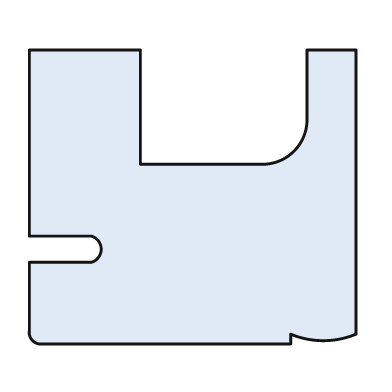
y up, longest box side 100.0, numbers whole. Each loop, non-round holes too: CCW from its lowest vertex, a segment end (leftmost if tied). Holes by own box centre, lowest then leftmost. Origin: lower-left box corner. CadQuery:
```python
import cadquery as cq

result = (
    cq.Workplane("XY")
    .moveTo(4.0, 0.0)
    .lineTo(80.0, 0.0)
    .lineTo(80.0, 3.0)
    .threePointArc((90.0, 1.0), (100.0, 3.0))
    .lineTo(100.0, 90.0)
    .lineTo(85.0, 90.0)
    .lineTo(85.0, 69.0)
    .threePointArc((81.0, 59.0), (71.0, 55.0))
    .lineTo(34.0, 55.0)
    .lineTo(34.0, 90.0)
    .lineTo(0.0, 90.0)
    .lineTo(0.0, 33.0)
    .lineTo(19.0, 33.0)
    .threePointArc((22.0, 29.0), (19.0, 25.0))
    .lineTo(0.0, 25.0)
    .lineTo(0.0, 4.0)
    .threePointArc((1.0, 1.0), (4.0, 0.0))
    .close()
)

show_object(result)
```